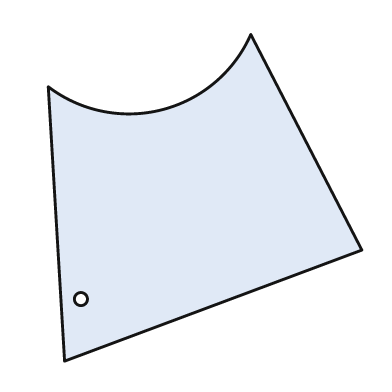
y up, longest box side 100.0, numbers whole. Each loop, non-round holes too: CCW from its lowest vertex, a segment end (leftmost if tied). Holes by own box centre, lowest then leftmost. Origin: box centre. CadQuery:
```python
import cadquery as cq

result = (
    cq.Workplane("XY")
    .moveTo(-43.0, -50.0)
    .lineTo(48.0, -16.0)
    .lineTo(14.0, 50.0)
    .threePointArc((-13.0, 27.0), (-48.0, 34.0))
    .close()
    .moveTo(-38.0, -31.0)
    .circle(2.0)
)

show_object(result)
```